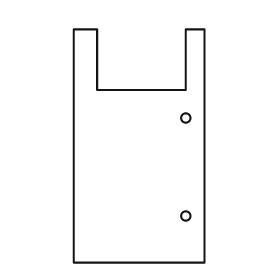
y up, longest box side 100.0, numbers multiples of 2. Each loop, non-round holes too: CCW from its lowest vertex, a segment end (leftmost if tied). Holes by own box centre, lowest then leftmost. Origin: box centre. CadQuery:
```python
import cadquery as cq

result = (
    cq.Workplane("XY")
    .moveTo(-28.0, -50.0)
    .lineTo(28.0, -50.0)
    .lineTo(28.0, 50.0)
    .lineTo(20.0, 50.0)
    .lineTo(20.0, 24.0)
    .lineTo(-18.0, 24.0)
    .lineTo(-18.0, 50.0)
    .lineTo(-28.0, 50.0)
    .close()
    .moveTo(20.0, -30.0)
    .circle(2.0)
    .moveTo(20.0, 12.0)
    .circle(2.0)
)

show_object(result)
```